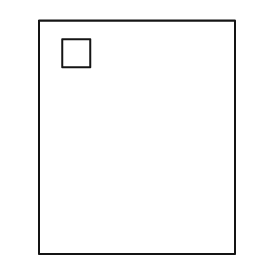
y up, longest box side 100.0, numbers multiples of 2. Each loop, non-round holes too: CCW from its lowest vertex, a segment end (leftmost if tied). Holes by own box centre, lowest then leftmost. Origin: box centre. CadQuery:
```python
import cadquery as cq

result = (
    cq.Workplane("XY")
    .moveTo(-42.0, -50.0)
    .lineTo(42.0, -50.0)
    .lineTo(42.0, 50.0)
    .lineTo(-42.0, 50.0)
    .close()
    .moveTo(-32.0, 30.0)
    .lineTo(-20.0, 30.0)
    .lineTo(-20.0, 42.0)
    .lineTo(-32.0, 42.0)
    .close()
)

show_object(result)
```